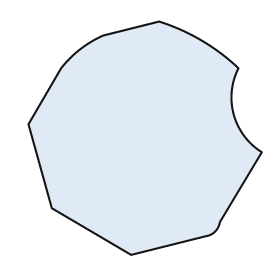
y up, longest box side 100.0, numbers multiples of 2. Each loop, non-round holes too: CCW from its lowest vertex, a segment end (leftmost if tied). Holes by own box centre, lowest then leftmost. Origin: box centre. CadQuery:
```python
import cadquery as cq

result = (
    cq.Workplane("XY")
    .moveTo(-6.0, -50.0)
    .lineTo(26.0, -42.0)
    .threePointArc((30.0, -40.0), (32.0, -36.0))
    .lineTo(50.0, -6.0)
    .threePointArc((38.0, 10.0), (40.0, 30.0))
    .threePointArc((24.0, 42.0), (6.0, 50.0))
    .lineTo(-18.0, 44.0)
    .threePointArc((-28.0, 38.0), (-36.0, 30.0))
    .lineTo(-50.0, 6.0)
    .lineTo(-40.0, -30.0)
    .close()
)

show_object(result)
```